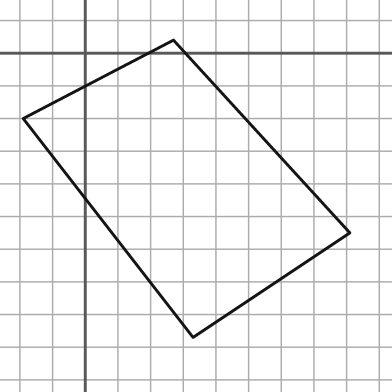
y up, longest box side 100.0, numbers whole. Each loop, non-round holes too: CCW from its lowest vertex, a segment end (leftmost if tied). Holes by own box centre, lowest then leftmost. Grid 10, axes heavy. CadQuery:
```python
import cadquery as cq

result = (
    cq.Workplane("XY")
    .moveTo(33.0, -87.0)
    .lineTo(81.0, -55.0)
    .lineTo(27.0, 4.0)
    .lineTo(-19.0, -20.0)
    .close()
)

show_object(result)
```